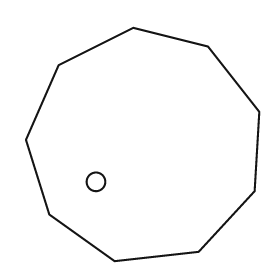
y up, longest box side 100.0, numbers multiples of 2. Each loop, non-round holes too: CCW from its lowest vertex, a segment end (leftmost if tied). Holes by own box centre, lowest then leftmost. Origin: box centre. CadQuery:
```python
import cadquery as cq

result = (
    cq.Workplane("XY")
    .moveTo(-12.0, -50.0)
    .lineTo(24.0, -46.0)
    .lineTo(48.0, -20.0)
    .lineTo(50.0, 14.0)
    .lineTo(28.0, 42.0)
    .lineTo(-4.0, 50.0)
    .lineTo(-36.0, 34.0)
    .lineTo(-50.0, 2.0)
    .lineTo(-40.0, -30.0)
    .close()
    .moveTo(-20.0, -16.0)
    .circle(4.0)
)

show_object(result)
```